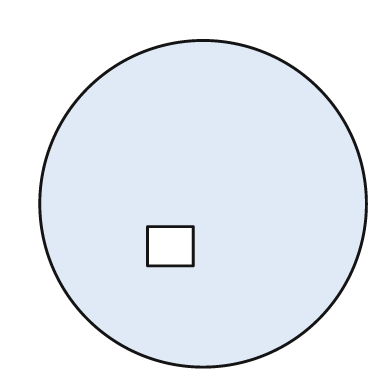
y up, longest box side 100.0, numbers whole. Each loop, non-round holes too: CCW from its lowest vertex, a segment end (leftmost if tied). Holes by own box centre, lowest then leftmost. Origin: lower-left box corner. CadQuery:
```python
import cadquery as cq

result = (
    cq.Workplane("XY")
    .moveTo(50.0, 50.0)
    .circle(50.0)
    .moveTo(33.0, 31.0)
    .lineTo(47.0, 31.0)
    .lineTo(47.0, 43.0)
    .lineTo(33.0, 43.0)
    .close()
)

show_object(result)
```